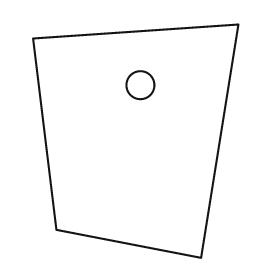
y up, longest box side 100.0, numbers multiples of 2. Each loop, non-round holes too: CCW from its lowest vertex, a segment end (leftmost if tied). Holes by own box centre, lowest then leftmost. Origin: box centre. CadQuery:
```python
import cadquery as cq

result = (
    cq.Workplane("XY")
    .moveTo(28.0, -50.0)
    .lineTo(44.0, 50.0)
    .lineTo(-44.0, 44.0)
    .lineTo(-34.0, -38.0)
    .close()
    .moveTo(2.0, 24.0)
    .circle(6.0)
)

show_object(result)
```